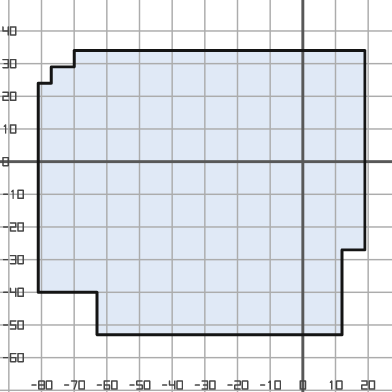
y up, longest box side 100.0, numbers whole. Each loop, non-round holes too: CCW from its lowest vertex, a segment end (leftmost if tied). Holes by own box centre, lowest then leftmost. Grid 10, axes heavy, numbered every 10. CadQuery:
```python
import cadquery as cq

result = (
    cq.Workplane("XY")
    .moveTo(-63.0, -53.0)
    .lineTo(12.0, -53.0)
    .lineTo(12.0, -27.0)
    .lineTo(19.0, -27.0)
    .lineTo(19.0, 34.0)
    .lineTo(-70.0, 34.0)
    .lineTo(-70.0, 29.0)
    .lineTo(-77.0, 29.0)
    .lineTo(-77.0, 24.0)
    .lineTo(-81.0, 24.0)
    .lineTo(-81.0, -40.0)
    .lineTo(-63.0, -40.0)
    .close()
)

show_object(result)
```